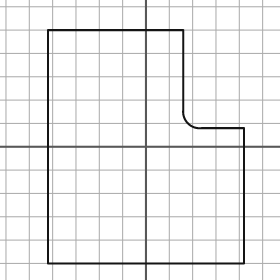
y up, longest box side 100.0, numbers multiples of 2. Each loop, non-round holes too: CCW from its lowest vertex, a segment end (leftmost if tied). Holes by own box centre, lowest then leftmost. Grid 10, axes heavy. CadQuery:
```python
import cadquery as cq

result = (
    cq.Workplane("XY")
    .moveTo(-42.0, -50.0)
    .lineTo(42.0, -50.0)
    .lineTo(42.0, 8.0)
    .lineTo(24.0, 8.0)
    .threePointArc((18.0, 10.0), (16.0, 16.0))
    .lineTo(16.0, 50.0)
    .lineTo(-42.0, 50.0)
    .close()
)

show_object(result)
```